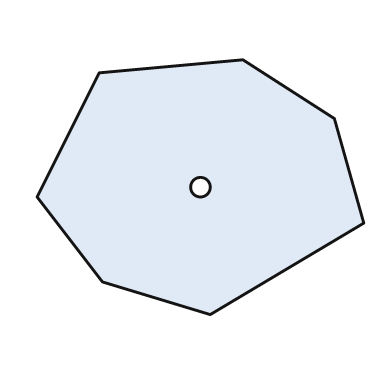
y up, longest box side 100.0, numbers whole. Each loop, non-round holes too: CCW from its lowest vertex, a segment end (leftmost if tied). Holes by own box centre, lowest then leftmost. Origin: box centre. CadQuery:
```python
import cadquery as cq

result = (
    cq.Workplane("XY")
    .moveTo(3.0, -39.0)
    .lineTo(50.0, -11.0)
    .lineTo(41.0, 21.0)
    .lineTo(13.0, 39.0)
    .lineTo(-31.0, 35.0)
    .lineTo(-50.0, -3.0)
    .lineTo(-30.0, -29.0)
    .close()
    .moveTo(0.0, 0.0)
    .circle(3.0)
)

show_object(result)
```